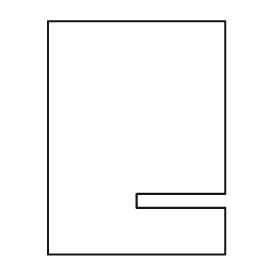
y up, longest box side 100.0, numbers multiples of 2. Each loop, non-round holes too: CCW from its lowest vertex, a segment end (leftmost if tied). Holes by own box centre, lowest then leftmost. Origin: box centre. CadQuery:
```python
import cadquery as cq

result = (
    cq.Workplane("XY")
    .moveTo(-38.0, -50.0)
    .lineTo(38.0, -50.0)
    .lineTo(38.0, -30.0)
    .lineTo(0.0, -30.0)
    .lineTo(0.0, -24.0)
    .lineTo(38.0, -24.0)
    .lineTo(38.0, 50.0)
    .lineTo(-38.0, 50.0)
    .close()
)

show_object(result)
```